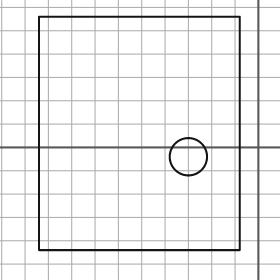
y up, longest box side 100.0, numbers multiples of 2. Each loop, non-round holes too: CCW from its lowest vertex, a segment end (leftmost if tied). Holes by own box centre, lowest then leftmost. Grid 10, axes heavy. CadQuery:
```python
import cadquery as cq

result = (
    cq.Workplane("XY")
    .moveTo(-94.0, -44.0)
    .lineTo(-8.0, -44.0)
    .lineTo(-8.0, 56.0)
    .lineTo(-94.0, 56.0)
    .close()
    .moveTo(-30.0, -4.0)
    .circle(8.0)
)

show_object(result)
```